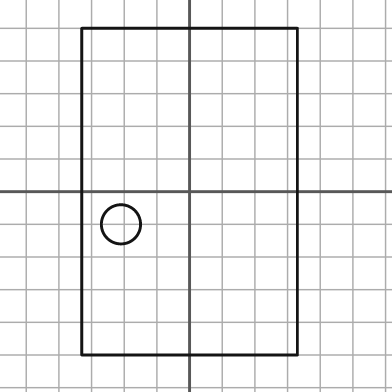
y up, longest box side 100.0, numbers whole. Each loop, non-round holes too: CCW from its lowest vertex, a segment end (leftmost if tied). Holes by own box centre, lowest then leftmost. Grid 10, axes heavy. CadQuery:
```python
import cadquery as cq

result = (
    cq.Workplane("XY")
    .moveTo(-33.0, -50.0)
    .lineTo(33.0, -50.0)
    .lineTo(33.0, 50.0)
    .lineTo(-33.0, 50.0)
    .close()
    .moveTo(-21.0, -10.0)
    .circle(6.0)
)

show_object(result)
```